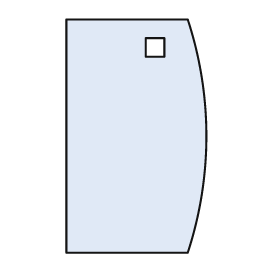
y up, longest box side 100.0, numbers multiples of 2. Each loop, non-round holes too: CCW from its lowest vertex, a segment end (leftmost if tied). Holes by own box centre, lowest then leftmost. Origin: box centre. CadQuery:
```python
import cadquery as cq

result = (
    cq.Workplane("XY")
    .moveTo(-30.0, -50.0)
    .lineTo(22.0, -50.0)
    .threePointArc((30.0, 0.0), (22.0, 50.0))
    .lineTo(-30.0, 50.0)
    .close()
    .moveTo(4.0, 34.0)
    .lineTo(12.0, 34.0)
    .lineTo(12.0, 42.0)
    .lineTo(4.0, 42.0)
    .close()
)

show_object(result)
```